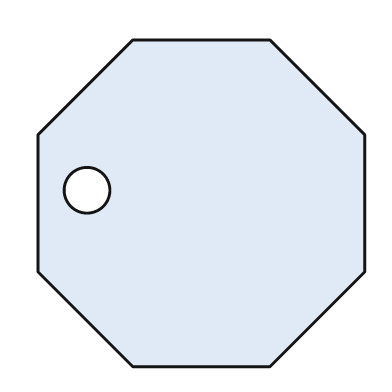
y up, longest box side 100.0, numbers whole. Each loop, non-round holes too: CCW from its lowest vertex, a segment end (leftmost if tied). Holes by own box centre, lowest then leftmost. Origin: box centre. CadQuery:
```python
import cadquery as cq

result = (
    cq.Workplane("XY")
    .moveTo(-21.0, -50.0)
    .lineTo(21.0, -50.0)
    .lineTo(50.0, -21.0)
    .lineTo(50.0, 21.0)
    .lineTo(21.0, 50.0)
    .lineTo(-21.0, 50.0)
    .lineTo(-50.0, 21.0)
    .lineTo(-50.0, -21.0)
    .close()
    .moveTo(-35.0, 4.0)
    .circle(7.0)
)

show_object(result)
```